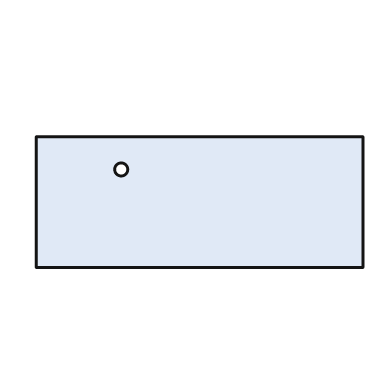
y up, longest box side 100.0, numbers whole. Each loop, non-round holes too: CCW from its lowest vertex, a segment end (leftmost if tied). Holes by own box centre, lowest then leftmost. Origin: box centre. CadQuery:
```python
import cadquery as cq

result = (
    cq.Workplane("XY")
    .moveTo(-50.0, -20.0)
    .lineTo(50.0, -20.0)
    .lineTo(50.0, 20.0)
    .lineTo(-50.0, 20.0)
    .close()
    .moveTo(-24.0, 10.0)
    .circle(2.0)
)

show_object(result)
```